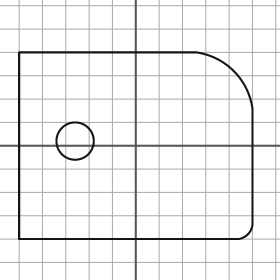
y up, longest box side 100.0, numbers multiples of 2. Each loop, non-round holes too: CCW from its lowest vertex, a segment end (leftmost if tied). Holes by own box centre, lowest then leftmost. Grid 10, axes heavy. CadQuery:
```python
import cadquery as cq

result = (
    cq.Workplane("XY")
    .moveTo(-50.0, -40.0)
    .lineTo(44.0, -40.0)
    .threePointArc((48.0, -38.0), (50.0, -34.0))
    .lineTo(50.0, 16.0)
    .threePointArc((42.0, 32.0), (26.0, 40.0))
    .lineTo(-50.0, 40.0)
    .close()
    .moveTo(-26.0, 2.0)
    .circle(8.0)
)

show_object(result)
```